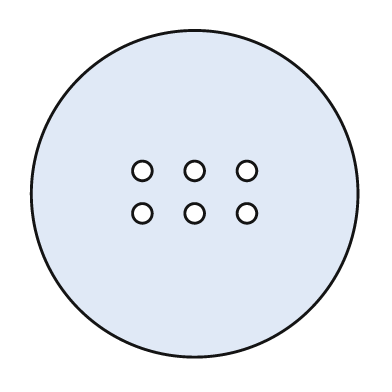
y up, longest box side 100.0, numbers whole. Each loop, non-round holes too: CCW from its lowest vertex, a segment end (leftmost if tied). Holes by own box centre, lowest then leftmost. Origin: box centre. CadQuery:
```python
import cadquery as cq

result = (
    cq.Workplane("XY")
    .moveTo(0.0, 0.0)
    .circle(50.0)
    .moveTo(-16.0, -6.0)
    .circle(3.0)
    .moveTo(0.0, -6.0)
    .circle(3.0)
    .moveTo(16.0, -6.0)
    .circle(3.0)
    .moveTo(-16.0, 7.0)
    .circle(3.0)
    .moveTo(0.0, 7.0)
    .circle(3.0)
    .moveTo(16.0, 7.0)
    .circle(3.0)
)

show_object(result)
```